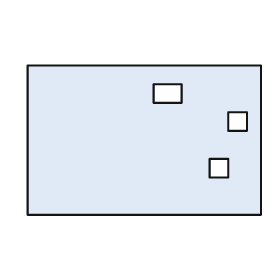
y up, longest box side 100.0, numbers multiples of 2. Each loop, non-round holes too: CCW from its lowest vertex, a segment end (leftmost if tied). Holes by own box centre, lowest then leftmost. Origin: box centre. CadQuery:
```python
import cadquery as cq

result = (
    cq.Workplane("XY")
    .moveTo(-50.0, -32.0)
    .lineTo(50.0, -32.0)
    .lineTo(50.0, 32.0)
    .lineTo(-50.0, 32.0)
    .close()
    .moveTo(28.0, -16.0)
    .lineTo(36.0, -16.0)
    .lineTo(36.0, -8.0)
    .lineTo(28.0, -8.0)
    .close()
    .moveTo(36.0, 4.0)
    .lineTo(44.0, 4.0)
    .lineTo(44.0, 12.0)
    .lineTo(36.0, 12.0)
    .close()
    .moveTo(4.0, 16.0)
    .lineTo(16.0, 16.0)
    .lineTo(16.0, 24.0)
    .lineTo(4.0, 24.0)
    .close()
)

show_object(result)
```